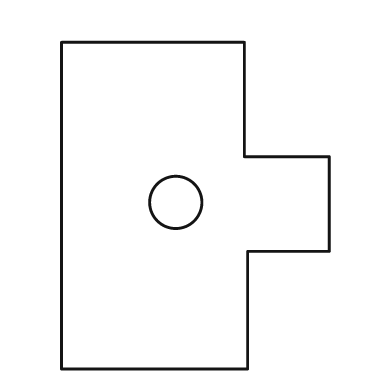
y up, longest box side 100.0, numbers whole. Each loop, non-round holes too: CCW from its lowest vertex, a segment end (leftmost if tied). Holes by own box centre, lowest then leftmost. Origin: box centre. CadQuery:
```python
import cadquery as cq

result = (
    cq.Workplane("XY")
    .moveTo(-41.0, -50.0)
    .lineTo(16.0, -50.0)
    .lineTo(16.0, -14.0)
    .lineTo(41.0, -14.0)
    .lineTo(41.0, 15.0)
    .lineTo(15.0, 15.0)
    .lineTo(15.0, 50.0)
    .lineTo(-41.0, 50.0)
    .close()
    .moveTo(-6.0, 1.0)
    .circle(8.0)
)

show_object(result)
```